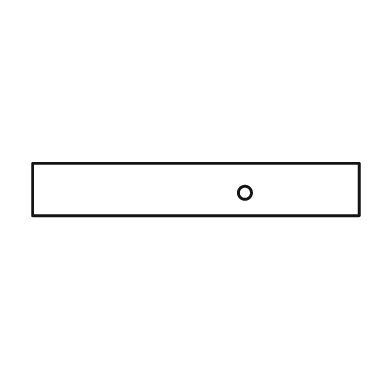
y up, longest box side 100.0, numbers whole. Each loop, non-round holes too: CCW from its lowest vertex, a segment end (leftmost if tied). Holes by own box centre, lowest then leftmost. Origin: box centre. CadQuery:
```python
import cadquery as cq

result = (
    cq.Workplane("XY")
    .moveTo(-50.0, -8.0)
    .lineTo(50.0, -8.0)
    .lineTo(50.0, 8.0)
    .lineTo(-50.0, 8.0)
    .close()
    .moveTo(15.0, -1.0)
    .circle(2.0)
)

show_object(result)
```